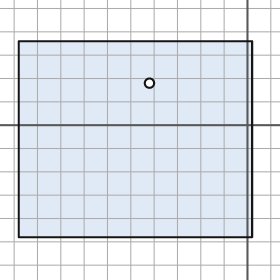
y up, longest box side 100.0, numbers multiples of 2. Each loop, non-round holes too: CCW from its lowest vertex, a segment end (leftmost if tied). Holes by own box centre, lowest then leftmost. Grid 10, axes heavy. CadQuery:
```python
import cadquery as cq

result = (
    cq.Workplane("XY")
    .moveTo(-98.0, -48.0)
    .lineTo(2.0, -48.0)
    .lineTo(2.0, 36.0)
    .lineTo(-98.0, 36.0)
    .close()
    .moveTo(-42.0, 18.0)
    .circle(2.0)
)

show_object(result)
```